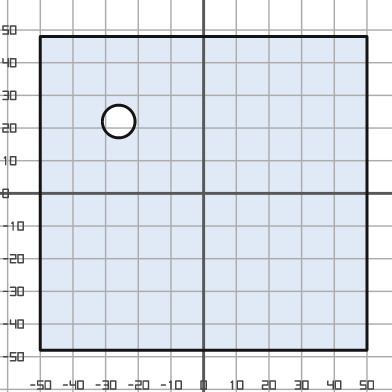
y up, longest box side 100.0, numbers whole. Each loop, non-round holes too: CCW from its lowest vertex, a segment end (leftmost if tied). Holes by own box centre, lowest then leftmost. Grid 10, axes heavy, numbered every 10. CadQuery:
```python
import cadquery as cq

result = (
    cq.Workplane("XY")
    .moveTo(-50.0, -48.0)
    .lineTo(50.0, -48.0)
    .lineTo(50.0, 48.0)
    .lineTo(-50.0, 48.0)
    .close()
    .moveTo(-26.0, 22.0)
    .circle(5.0)
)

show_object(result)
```